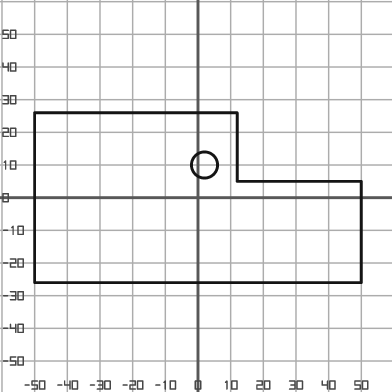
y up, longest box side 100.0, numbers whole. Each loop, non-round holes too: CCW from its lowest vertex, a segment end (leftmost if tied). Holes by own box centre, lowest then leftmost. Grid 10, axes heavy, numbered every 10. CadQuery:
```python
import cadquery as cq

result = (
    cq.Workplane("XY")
    .moveTo(-50.0, -26.0)
    .lineTo(50.0, -26.0)
    .lineTo(50.0, 5.0)
    .lineTo(12.0, 5.0)
    .lineTo(12.0, 26.0)
    .lineTo(-50.0, 26.0)
    .close()
    .moveTo(2.0, 10.0)
    .circle(4.0)
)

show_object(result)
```